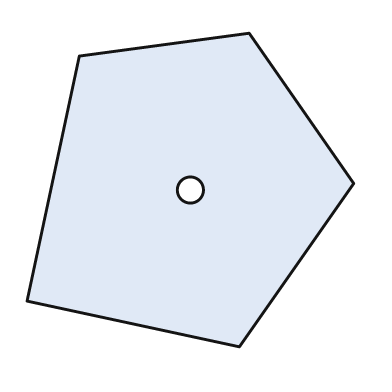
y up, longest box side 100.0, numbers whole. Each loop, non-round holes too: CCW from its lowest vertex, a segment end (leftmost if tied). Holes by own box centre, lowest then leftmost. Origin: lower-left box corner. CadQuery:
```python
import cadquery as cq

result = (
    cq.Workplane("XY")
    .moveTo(65.0, 0.0)
    .lineTo(100.0, 50.0)
    .lineTo(68.0, 96.0)
    .lineTo(16.0, 89.0)
    .lineTo(0.0, 14.0)
    .close()
    .moveTo(50.0, 48.0)
    .circle(4.0)
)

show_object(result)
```